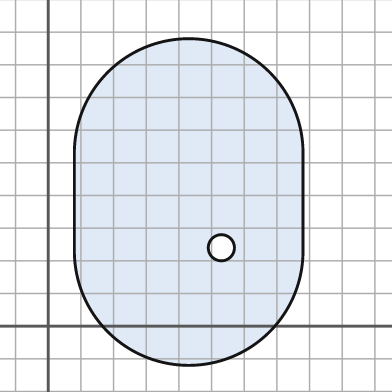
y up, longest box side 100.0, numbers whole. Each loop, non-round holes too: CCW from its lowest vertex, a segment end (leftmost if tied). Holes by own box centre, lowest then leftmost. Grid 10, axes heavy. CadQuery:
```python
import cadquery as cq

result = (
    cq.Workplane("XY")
    .moveTo(8.0, 23.0)
    .threePointArc((43.0, -12.0), (78.0, 23.0))
    .lineTo(78.0, 53.0)
    .threePointArc((43.0, 88.0), (8.0, 53.0))
    .close()
    .moveTo(53.0, 24.0)
    .circle(4.0)
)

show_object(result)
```